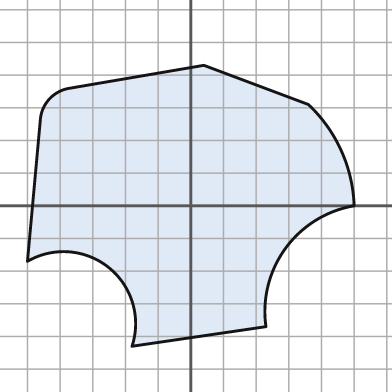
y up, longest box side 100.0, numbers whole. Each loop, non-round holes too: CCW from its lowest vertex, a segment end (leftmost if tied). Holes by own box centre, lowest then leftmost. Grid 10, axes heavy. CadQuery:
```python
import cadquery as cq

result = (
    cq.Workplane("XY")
    .moveTo(-18.0, -43.0)
    .lineTo(23.0, -37.0)
    .threePointArc((29.0, -13.0), (50.0, 0.0))
    .threePointArc((46.0, 17.0), (36.0, 31.0))
    .lineTo(4.0, 43.0)
    .lineTo(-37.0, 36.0)
    .threePointArc((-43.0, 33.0), (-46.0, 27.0))
    .lineTo(-50.0, -17.0)
    .threePointArc((-25.0, -19.0), (-18.0, -43.0))
    .close()
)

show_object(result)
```